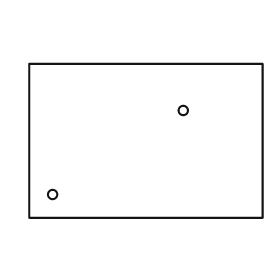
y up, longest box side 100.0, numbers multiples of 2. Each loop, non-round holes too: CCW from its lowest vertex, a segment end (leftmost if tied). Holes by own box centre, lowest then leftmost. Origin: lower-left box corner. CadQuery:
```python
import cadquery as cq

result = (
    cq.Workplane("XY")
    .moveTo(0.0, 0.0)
    .lineTo(100.0, 0.0)
    .lineTo(100.0, 66.0)
    .lineTo(0.0, 66.0)
    .close()
    .moveTo(10.0, 10.0)
    .circle(2.0)
    .moveTo(66.0, 46.0)
    .circle(2.0)
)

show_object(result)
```